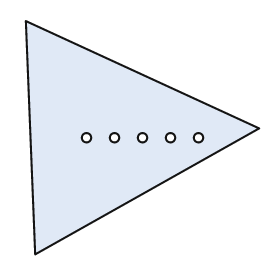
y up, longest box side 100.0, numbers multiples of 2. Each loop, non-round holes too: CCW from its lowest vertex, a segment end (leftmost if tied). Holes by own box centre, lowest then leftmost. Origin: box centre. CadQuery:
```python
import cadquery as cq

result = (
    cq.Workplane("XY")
    .moveTo(-46.0, -50.0)
    .lineTo(50.0, 4.0)
    .lineTo(-50.0, 50.0)
    .close()
    .moveTo(-24.0, 0.0)
    .circle(2.0)
    .moveTo(-12.0, 0.0)
    .circle(2.0)
    .moveTo(0.0, 0.0)
    .circle(2.0)
    .moveTo(12.0, 0.0)
    .circle(2.0)
    .moveTo(24.0, 0.0)
    .circle(2.0)
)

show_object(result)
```